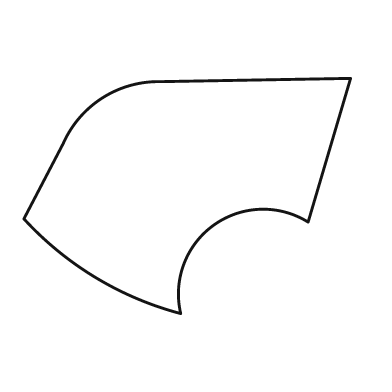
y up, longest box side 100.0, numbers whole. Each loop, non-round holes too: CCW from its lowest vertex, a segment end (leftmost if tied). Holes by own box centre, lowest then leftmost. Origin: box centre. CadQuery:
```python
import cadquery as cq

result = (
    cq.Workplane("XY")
    .moveTo(-2.0, -36.0)
    .threePointArc((8.0, -9.0), (37.0, -8.0))
    .lineTo(50.0, 36.0)
    .lineTo(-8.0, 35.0)
    .threePointArc((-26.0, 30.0), (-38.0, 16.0))
    .lineTo(-50.0, -7.0)
    .threePointArc((-28.0, -25.0), (-2.0, -36.0))
    .close()
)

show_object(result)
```